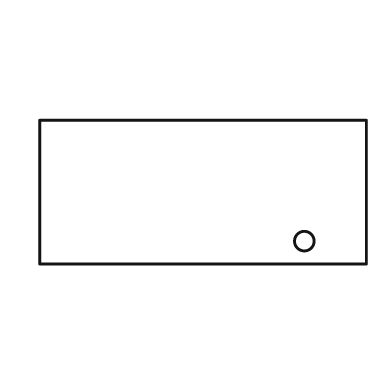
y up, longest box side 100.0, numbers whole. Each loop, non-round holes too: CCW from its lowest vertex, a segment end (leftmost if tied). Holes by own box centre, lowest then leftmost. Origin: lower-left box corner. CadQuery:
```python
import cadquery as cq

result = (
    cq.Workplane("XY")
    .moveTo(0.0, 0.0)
    .lineTo(100.0, 0.0)
    .lineTo(100.0, 44.0)
    .lineTo(0.0, 44.0)
    .close()
    .moveTo(81.0, 7.0)
    .circle(3.0)
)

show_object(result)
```